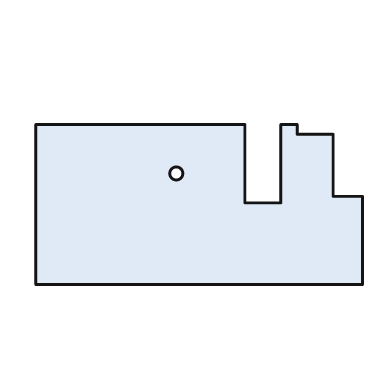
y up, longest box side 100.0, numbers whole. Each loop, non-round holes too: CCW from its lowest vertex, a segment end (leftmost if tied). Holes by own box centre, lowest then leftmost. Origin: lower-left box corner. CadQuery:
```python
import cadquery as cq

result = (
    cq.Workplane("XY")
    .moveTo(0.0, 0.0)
    .lineTo(100.0, 0.0)
    .lineTo(100.0, 27.0)
    .lineTo(91.0, 27.0)
    .lineTo(91.0, 46.0)
    .lineTo(80.0, 46.0)
    .lineTo(80.0, 49.0)
    .lineTo(75.0, 49.0)
    .lineTo(75.0, 25.0)
    .lineTo(64.0, 25.0)
    .lineTo(64.0, 49.0)
    .lineTo(0.0, 49.0)
    .close()
    .moveTo(43.0, 34.0)
    .circle(2.0)
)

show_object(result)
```